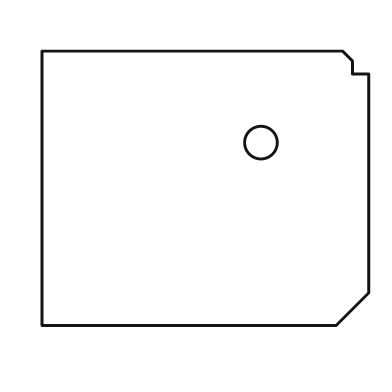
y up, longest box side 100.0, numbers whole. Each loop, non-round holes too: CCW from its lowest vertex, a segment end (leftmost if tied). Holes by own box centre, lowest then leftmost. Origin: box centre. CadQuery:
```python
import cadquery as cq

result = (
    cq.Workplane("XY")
    .moveTo(-50.0, -42.0)
    .lineTo(40.0, -42.0)
    .lineTo(50.0, -32.0)
    .lineTo(50.0, 35.0)
    .lineTo(45.0, 35.0)
    .lineTo(45.0, 39.0)
    .lineTo(42.0, 42.0)
    .lineTo(-50.0, 42.0)
    .close()
    .moveTo(17.0, 14.0)
    .circle(5.0)
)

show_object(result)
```